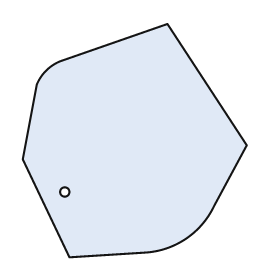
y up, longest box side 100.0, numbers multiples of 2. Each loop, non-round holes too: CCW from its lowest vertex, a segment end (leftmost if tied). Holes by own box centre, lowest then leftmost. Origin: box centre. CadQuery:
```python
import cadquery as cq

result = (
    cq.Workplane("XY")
    .moveTo(-28.0, -50.0)
    .lineTo(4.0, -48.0)
    .threePointArc((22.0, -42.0), (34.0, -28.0))
    .lineTo(48.0, -2.0)
    .lineTo(14.0, 50.0)
    .lineTo(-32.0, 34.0)
    .threePointArc((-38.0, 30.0), (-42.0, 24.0))
    .lineTo(-48.0, -8.0)
    .close()
    .moveTo(-30.0, -22.0)
    .circle(2.0)
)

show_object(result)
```